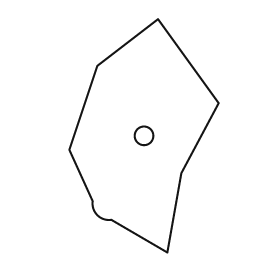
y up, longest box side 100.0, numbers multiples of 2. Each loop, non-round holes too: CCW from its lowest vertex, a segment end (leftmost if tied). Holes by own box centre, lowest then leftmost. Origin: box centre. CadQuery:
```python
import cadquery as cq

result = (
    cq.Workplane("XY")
    .moveTo(10.0, -50.0)
    .lineTo(16.0, -16.0)
    .lineTo(32.0, 14.0)
    .lineTo(6.0, 50.0)
    .lineTo(-20.0, 30.0)
    .lineTo(-32.0, -6.0)
    .lineTo(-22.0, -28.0)
    .threePointArc((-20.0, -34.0), (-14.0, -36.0))
    .close()
    .moveTo(0.0, 0.0)
    .circle(4.0)
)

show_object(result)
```